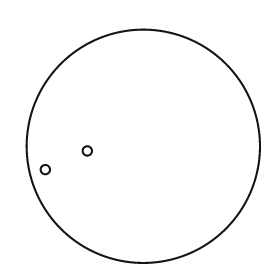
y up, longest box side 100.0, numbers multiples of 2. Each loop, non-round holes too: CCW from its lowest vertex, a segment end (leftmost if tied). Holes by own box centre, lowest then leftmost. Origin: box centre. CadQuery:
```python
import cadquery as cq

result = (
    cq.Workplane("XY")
    .moveTo(0.0, 0.0)
    .circle(50.0)
    .moveTo(-42.0, -10.0)
    .circle(2.0)
    .moveTo(-24.0, -2.0)
    .circle(2.0)
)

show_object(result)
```